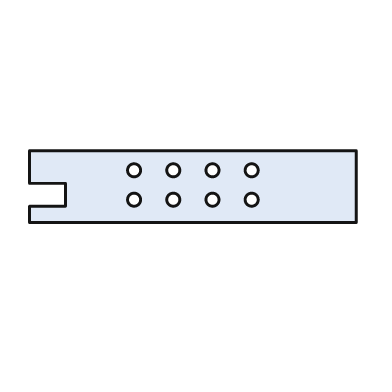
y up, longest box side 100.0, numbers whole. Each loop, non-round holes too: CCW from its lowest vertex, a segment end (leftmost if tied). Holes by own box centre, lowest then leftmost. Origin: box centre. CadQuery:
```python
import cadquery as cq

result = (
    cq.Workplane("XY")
    .moveTo(-50.0, -11.0)
    .lineTo(50.0, -11.0)
    .lineTo(50.0, 11.0)
    .lineTo(-50.0, 11.0)
    .lineTo(-50.0, 1.0)
    .lineTo(-39.0, 1.0)
    .lineTo(-39.0, -6.0)
    .lineTo(-50.0, -6.0)
    .close()
    .moveTo(-18.0, -4.0)
    .circle(2.0)
    .moveTo(-6.0, -4.0)
    .circle(2.0)
    .moveTo(6.0, -4.0)
    .circle(2.0)
    .moveTo(18.0, -4.0)
    .circle(2.0)
    .moveTo(-18.0, 5.0)
    .circle(2.0)
    .moveTo(-6.0, 5.0)
    .circle(2.0)
    .moveTo(6.0, 5.0)
    .circle(2.0)
    .moveTo(18.0, 5.0)
    .circle(2.0)
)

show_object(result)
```